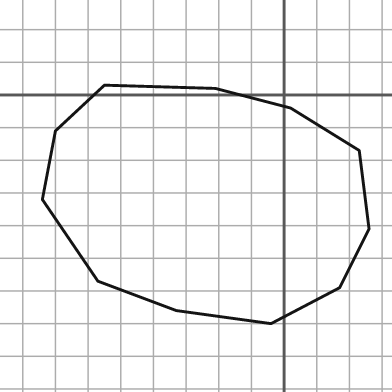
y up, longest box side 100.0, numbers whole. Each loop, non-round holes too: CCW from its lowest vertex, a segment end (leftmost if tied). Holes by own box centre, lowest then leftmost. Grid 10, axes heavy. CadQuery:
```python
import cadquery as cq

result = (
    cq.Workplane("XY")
    .moveTo(-4.0, -70.0)
    .lineTo(17.0, -59.0)
    .lineTo(26.0, -41.0)
    .lineTo(23.0, -17.0)
    .lineTo(2.0, -4.0)
    .lineTo(-21.0, 2.0)
    .lineTo(-55.0, 3.0)
    .lineTo(-70.0, -11.0)
    .lineTo(-74.0, -32.0)
    .lineTo(-57.0, -57.0)
    .lineTo(-33.0, -66.0)
    .close()
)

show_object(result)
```